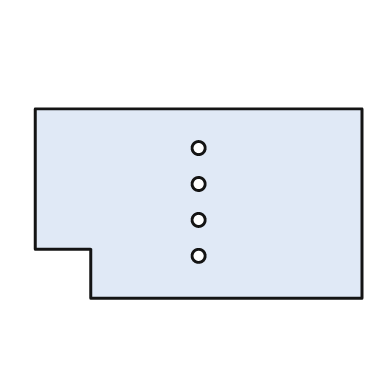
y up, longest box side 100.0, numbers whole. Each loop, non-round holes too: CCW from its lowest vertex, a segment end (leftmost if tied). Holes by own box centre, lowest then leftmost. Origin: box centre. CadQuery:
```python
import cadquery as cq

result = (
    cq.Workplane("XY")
    .moveTo(-33.0, -29.0)
    .lineTo(50.0, -29.0)
    .lineTo(50.0, 29.0)
    .lineTo(-50.0, 29.0)
    .lineTo(-50.0, -14.0)
    .lineTo(-33.0, -14.0)
    .close()
    .moveTo(0.0, -16.0)
    .circle(2.0)
    .moveTo(0.0, -5.0)
    .circle(2.0)
    .moveTo(0.0, 6.0)
    .circle(2.0)
    .moveTo(0.0, 17.0)
    .circle(2.0)
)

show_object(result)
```